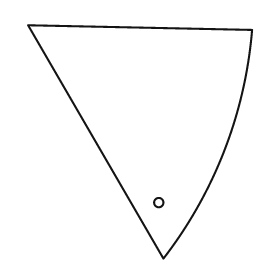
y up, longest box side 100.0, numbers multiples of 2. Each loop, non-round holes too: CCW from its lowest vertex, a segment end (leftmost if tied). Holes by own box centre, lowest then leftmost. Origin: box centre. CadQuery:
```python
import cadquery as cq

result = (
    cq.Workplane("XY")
    .moveTo(10.0, -50.0)
    .threePointArc((36.0, -4.0), (48.0, 48.0))
    .lineTo(-48.0, 50.0)
    .close()
    .moveTo(8.0, -26.0)
    .circle(2.0)
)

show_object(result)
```